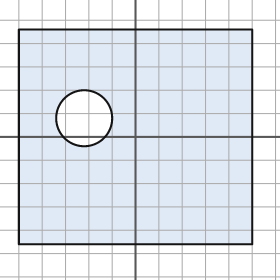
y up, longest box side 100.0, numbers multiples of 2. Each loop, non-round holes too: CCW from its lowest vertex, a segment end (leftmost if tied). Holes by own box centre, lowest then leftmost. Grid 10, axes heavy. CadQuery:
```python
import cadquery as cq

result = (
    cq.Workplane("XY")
    .moveTo(-50.0, -46.0)
    .lineTo(50.0, -46.0)
    .lineTo(50.0, 46.0)
    .lineTo(-50.0, 46.0)
    .close()
    .moveTo(-22.0, 8.0)
    .circle(12.0)
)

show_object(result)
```